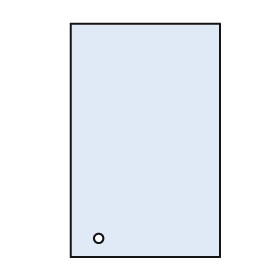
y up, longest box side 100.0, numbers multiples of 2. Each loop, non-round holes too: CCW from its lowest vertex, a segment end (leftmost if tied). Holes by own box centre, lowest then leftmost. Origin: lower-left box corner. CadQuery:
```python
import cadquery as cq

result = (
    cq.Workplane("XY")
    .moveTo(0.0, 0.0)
    .lineTo(64.0, 0.0)
    .lineTo(64.0, 100.0)
    .lineTo(0.0, 100.0)
    .close()
    .moveTo(12.0, 8.0)
    .circle(2.0)
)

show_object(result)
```